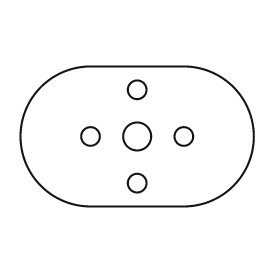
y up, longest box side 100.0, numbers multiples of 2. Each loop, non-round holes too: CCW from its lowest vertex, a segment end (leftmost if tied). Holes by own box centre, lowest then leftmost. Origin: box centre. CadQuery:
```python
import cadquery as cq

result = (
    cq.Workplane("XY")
    .moveTo(-20.0, -30.0)
    .lineTo(20.0, -30.0)
    .threePointArc((50.0, 0.0), (20.0, 30.0))
    .lineTo(-20.0, 30.0)
    .threePointArc((-50.0, 0.0), (-20.0, -30.0))
    .close()
    .moveTo(0.0, -20.0)
    .circle(4.0)
    .moveTo(-20.0, 0.0)
    .circle(4.0)
    .moveTo(0.0, 0.0)
    .circle(6.0)
    .moveTo(20.0, 0.0)
    .circle(4.0)
    .moveTo(0.0, 20.0)
    .circle(4.0)
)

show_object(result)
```